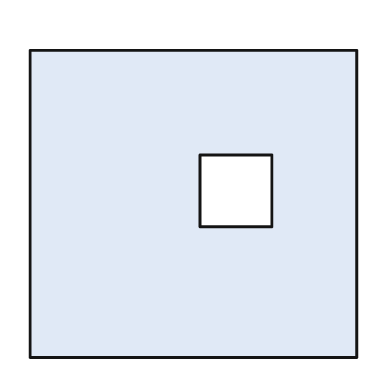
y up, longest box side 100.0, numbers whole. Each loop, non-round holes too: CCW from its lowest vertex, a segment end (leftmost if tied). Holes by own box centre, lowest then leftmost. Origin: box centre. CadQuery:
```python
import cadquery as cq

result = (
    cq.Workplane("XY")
    .moveTo(-50.0, -47.0)
    .lineTo(50.0, -47.0)
    .lineTo(50.0, 47.0)
    .lineTo(-50.0, 47.0)
    .close()
    .moveTo(2.0, -7.0)
    .lineTo(24.0, -7.0)
    .lineTo(24.0, 15.0)
    .lineTo(2.0, 15.0)
    .close()
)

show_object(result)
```